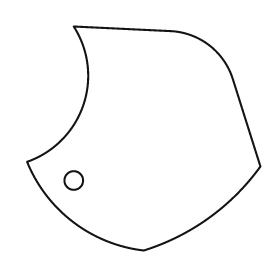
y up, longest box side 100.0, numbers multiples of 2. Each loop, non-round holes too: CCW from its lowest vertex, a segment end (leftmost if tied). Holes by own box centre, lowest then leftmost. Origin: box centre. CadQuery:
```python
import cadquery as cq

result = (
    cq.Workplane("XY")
    .moveTo(0.0, -48.0)
    .threePointArc((28.0, -34.0), (50.0, -12.0))
    .lineTo(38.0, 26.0)
    .threePointArc((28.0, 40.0), (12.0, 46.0))
    .lineTo(-30.0, 48.0)
    .threePointArc((-26.0, 14.0), (-50.0, -10.0))
    .threePointArc((-30.0, -36.0), (0.0, -48.0))
    .close()
    .moveTo(-30.0, -18.0)
    .circle(4.0)
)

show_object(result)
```